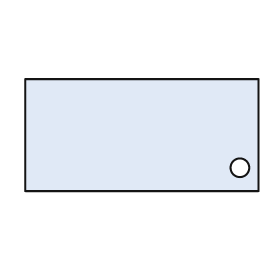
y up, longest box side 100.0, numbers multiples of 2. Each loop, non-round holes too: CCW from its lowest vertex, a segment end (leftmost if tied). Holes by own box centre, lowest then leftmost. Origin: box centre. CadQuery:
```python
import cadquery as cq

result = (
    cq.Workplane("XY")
    .moveTo(-50.0, -24.0)
    .lineTo(50.0, -24.0)
    .lineTo(50.0, 24.0)
    .lineTo(-50.0, 24.0)
    .close()
    .moveTo(42.0, -14.0)
    .circle(4.0)
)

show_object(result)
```